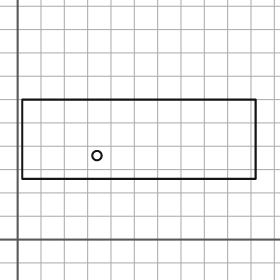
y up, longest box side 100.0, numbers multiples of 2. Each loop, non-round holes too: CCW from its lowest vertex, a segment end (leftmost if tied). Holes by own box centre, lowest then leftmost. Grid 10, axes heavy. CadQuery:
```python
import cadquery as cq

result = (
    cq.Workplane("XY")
    .moveTo(2.0, 26.0)
    .lineTo(102.0, 26.0)
    .lineTo(102.0, 60.0)
    .lineTo(2.0, 60.0)
    .close()
    .moveTo(34.0, 36.0)
    .circle(2.0)
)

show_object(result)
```